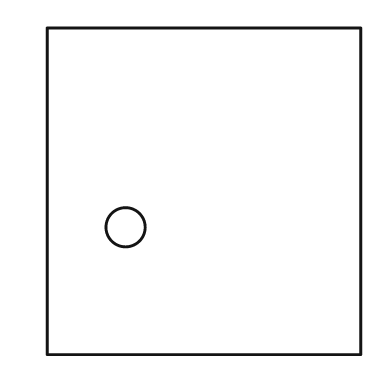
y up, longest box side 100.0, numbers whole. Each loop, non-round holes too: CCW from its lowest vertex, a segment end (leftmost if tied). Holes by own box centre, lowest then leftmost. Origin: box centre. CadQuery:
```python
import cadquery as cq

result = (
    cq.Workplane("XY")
    .moveTo(-48.0, -50.0)
    .lineTo(48.0, -50.0)
    .lineTo(48.0, 50.0)
    .lineTo(-48.0, 50.0)
    .close()
    .moveTo(-24.0, -11.0)
    .circle(6.0)
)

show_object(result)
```